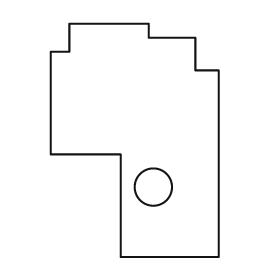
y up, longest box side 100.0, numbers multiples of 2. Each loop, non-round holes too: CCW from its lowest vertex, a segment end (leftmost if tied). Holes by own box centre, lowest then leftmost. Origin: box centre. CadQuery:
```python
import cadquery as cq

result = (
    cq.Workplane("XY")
    .moveTo(-6.0, -50.0)
    .lineTo(36.0, -50.0)
    .lineTo(36.0, 30.0)
    .lineTo(26.0, 30.0)
    .lineTo(26.0, 44.0)
    .lineTo(6.0, 44.0)
    .lineTo(6.0, 50.0)
    .lineTo(-28.0, 50.0)
    .lineTo(-28.0, 38.0)
    .lineTo(-36.0, 38.0)
    .lineTo(-36.0, -6.0)
    .lineTo(-6.0, -6.0)
    .close()
    .moveTo(8.0, -20.0)
    .circle(8.0)
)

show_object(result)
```